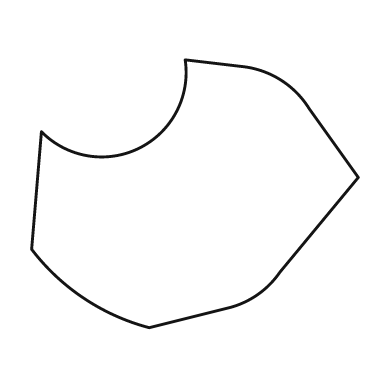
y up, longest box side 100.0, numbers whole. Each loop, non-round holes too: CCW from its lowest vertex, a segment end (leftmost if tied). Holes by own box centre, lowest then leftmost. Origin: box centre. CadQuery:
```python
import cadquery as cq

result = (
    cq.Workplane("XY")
    .moveTo(-14.0, -41.0)
    .lineTo(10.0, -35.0)
    .threePointArc((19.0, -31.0), (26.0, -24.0))
    .lineTo(50.0, 5.0)
    .lineTo(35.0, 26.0)
    .threePointArc((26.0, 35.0), (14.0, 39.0))
    .lineTo(-3.0, 41.0)
    .threePointArc((-17.0, 14.0), (-47.0, 19.0))
    .lineTo(-50.0, -17.0)
    .threePointArc((-34.0, -32.0), (-14.0, -41.0))
    .close()
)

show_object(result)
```